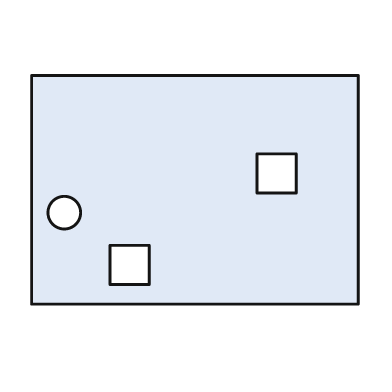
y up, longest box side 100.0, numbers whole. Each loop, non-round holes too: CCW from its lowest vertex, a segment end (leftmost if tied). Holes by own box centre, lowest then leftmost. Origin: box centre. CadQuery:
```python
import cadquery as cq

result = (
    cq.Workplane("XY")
    .moveTo(-50.0, -35.0)
    .lineTo(50.0, -35.0)
    .lineTo(50.0, 35.0)
    .lineTo(-50.0, 35.0)
    .close()
    .moveTo(-26.0, -29.0)
    .lineTo(-14.0, -29.0)
    .lineTo(-14.0, -17.0)
    .lineTo(-26.0, -17.0)
    .close()
    .moveTo(-40.0, -7.0)
    .circle(5.0)
    .moveTo(19.0, -1.0)
    .lineTo(31.0, -1.0)
    .lineTo(31.0, 11.0)
    .lineTo(19.0, 11.0)
    .close()
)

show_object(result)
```